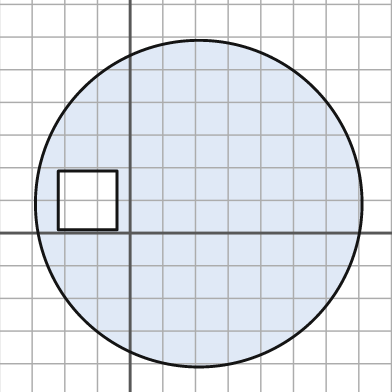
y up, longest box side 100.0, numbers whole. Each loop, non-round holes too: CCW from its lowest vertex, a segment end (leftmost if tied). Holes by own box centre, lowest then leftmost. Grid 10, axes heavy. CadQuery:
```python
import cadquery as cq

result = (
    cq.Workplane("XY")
    .moveTo(21.0, 9.0)
    .circle(50.0)
    .moveTo(-22.0, 1.0)
    .lineTo(-4.0, 1.0)
    .lineTo(-4.0, 19.0)
    .lineTo(-22.0, 19.0)
    .close()
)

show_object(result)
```